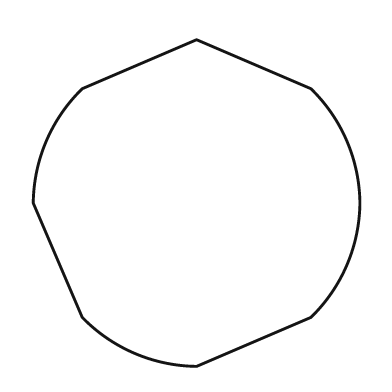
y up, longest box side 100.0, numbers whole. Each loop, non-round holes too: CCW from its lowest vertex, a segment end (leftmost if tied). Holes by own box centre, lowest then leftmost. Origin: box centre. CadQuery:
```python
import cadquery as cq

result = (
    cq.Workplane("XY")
    .moveTo(0.0, -50.0)
    .lineTo(35.0, -35.0)
    .threePointArc((46.0, -19.0), (50.0, 0.0))
    .threePointArc((46.0, 19.0), (35.0, 35.0))
    .lineTo(0.0, 50.0)
    .lineTo(-35.0, 35.0)
    .threePointArc((-46.0, 19.0), (-50.0, 0.0))
    .lineTo(-35.0, -35.0)
    .threePointArc((-19.0, -46.0), (0.0, -50.0))
    .close()
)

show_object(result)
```